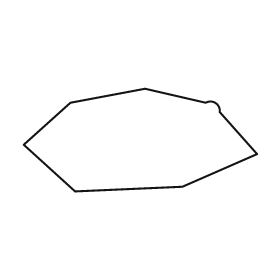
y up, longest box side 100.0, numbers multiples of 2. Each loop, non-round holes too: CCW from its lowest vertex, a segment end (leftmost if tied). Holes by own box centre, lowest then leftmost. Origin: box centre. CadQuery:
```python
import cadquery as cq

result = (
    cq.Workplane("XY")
    .moveTo(-28.0, -22.0)
    .lineTo(18.0, -20.0)
    .lineTo(50.0, -6.0)
    .lineTo(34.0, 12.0)
    .threePointArc((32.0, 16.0), (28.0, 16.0))
    .lineTo(2.0, 22.0)
    .lineTo(-30.0, 16.0)
    .lineTo(-50.0, -2.0)
    .close()
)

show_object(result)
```